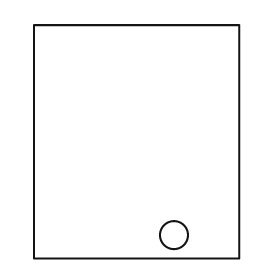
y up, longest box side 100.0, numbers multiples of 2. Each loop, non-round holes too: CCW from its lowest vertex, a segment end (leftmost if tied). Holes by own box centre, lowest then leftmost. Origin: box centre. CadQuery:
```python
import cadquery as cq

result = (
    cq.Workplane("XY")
    .moveTo(-44.0, -50.0)
    .lineTo(44.0, -50.0)
    .lineTo(44.0, 50.0)
    .lineTo(-44.0, 50.0)
    .close()
    .moveTo(16.0, -40.0)
    .circle(6.0)
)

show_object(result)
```